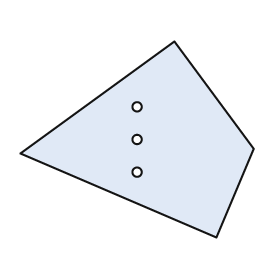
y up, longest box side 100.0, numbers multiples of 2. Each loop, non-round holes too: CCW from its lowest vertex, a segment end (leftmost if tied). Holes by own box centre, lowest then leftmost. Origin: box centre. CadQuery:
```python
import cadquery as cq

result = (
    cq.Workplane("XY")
    .moveTo(34.0, -42.0)
    .lineTo(50.0, -4.0)
    .lineTo(16.0, 42.0)
    .lineTo(-50.0, -6.0)
    .close()
    .moveTo(0.0, -14.0)
    .circle(2.0)
    .moveTo(0.0, 0.0)
    .circle(2.0)
    .moveTo(0.0, 14.0)
    .circle(2.0)
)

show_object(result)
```